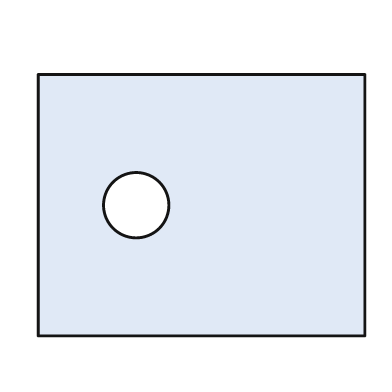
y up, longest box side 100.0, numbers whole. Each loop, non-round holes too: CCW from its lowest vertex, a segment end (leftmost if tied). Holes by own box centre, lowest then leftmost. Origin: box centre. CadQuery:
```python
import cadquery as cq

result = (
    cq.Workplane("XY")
    .moveTo(-50.0, -40.0)
    .lineTo(50.0, -40.0)
    .lineTo(50.0, 40.0)
    .lineTo(-50.0, 40.0)
    .close()
    .moveTo(-20.0, 0.0)
    .circle(10.0)
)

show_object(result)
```